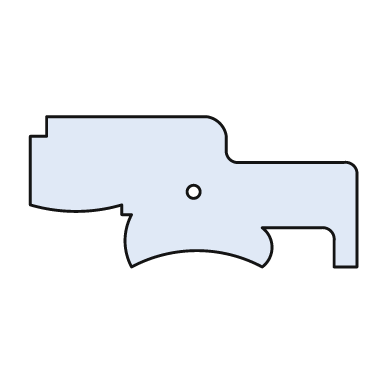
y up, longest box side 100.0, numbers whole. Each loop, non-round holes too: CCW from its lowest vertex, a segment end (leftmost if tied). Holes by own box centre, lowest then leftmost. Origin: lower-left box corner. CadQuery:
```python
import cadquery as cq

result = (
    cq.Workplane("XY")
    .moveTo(31.0, 0.0)
    .threePointArc((51.0, 5.0), (71.0, 0.0))
    .threePointArc((74.0, 6.0), (71.0, 12.0))
    .lineTo(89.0, 12.0)
    .threePointArc((92.0, 11.0), (93.0, 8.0))
    .lineTo(93.0, 0.0)
    .lineTo(100.0, 0.0)
    .lineTo(100.0, 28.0)
    .threePointArc((99.0, 31.0), (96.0, 32.0))
    .lineTo(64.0, 32.0)
    .threePointArc((61.0, 33.0), (60.0, 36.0))
    .lineTo(60.0, 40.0)
    .threePointArc((58.0, 44.0), (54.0, 46.0))
    .lineTo(5.0, 46.0)
    .lineTo(5.0, 40.0)
    .lineTo(0.0, 40.0)
    .lineTo(0.0, 19.0)
    .threePointArc((14.0, 17.0), (28.0, 19.0))
    .lineTo(28.0, 16.0)
    .lineTo(31.0, 16.0)
    .threePointArc((29.0, 8.0), (31.0, 0.0))
    .close()
    .moveTo(50.0, 23.0)
    .circle(2.0)
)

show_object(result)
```